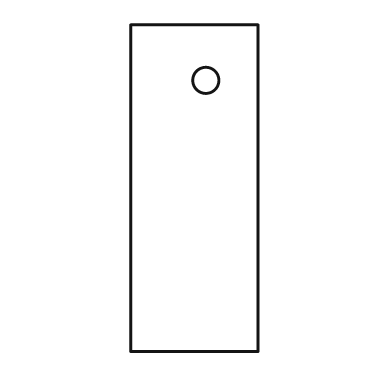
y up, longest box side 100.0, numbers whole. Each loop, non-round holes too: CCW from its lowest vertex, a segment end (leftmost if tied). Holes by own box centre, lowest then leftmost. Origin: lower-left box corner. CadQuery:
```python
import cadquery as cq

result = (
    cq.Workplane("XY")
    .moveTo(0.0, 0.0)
    .lineTo(39.0, 0.0)
    .lineTo(39.0, 100.0)
    .lineTo(0.0, 100.0)
    .close()
    .moveTo(23.0, 83.0)
    .circle(4.0)
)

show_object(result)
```